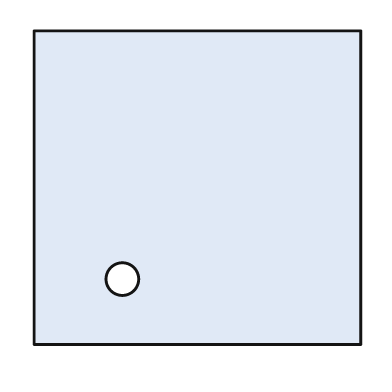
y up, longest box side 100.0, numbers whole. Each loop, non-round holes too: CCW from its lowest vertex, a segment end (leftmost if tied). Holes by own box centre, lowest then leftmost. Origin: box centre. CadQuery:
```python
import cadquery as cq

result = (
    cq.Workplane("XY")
    .moveTo(-50.0, -48.0)
    .lineTo(50.0, -48.0)
    .lineTo(50.0, 48.0)
    .lineTo(-50.0, 48.0)
    .close()
    .moveTo(-23.0, -28.0)
    .circle(5.0)
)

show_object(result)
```